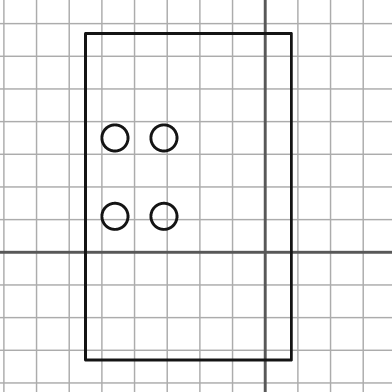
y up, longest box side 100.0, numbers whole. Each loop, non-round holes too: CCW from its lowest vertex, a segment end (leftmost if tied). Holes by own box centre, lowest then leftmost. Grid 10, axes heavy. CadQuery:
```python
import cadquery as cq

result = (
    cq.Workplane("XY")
    .moveTo(-55.0, -33.0)
    .lineTo(8.0, -33.0)
    .lineTo(8.0, 67.0)
    .lineTo(-55.0, 67.0)
    .close()
    .moveTo(-46.0, 11.0)
    .circle(4.0)
    .moveTo(-31.0, 11.0)
    .circle(4.0)
    .moveTo(-46.0, 35.0)
    .circle(4.0)
    .moveTo(-31.0, 35.0)
    .circle(4.0)
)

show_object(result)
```